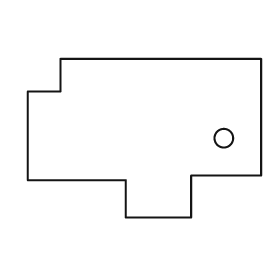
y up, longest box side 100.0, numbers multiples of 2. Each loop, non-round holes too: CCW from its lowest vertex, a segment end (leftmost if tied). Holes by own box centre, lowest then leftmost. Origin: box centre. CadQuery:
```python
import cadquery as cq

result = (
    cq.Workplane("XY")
    .moveTo(-8.0, -34.0)
    .lineTo(20.0, -34.0)
    .lineTo(20.0, -16.0)
    .lineTo(50.0, -16.0)
    .lineTo(50.0, 34.0)
    .lineTo(-36.0, 34.0)
    .lineTo(-36.0, 20.0)
    .lineTo(-50.0, 20.0)
    .lineTo(-50.0, -18.0)
    .lineTo(-8.0, -18.0)
    .close()
    .moveTo(34.0, 0.0)
    .circle(4.0)
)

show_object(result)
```